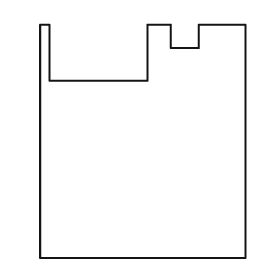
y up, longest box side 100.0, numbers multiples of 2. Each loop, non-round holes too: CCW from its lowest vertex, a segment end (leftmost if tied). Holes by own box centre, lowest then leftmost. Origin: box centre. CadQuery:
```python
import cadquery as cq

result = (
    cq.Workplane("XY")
    .moveTo(-44.0, -50.0)
    .lineTo(44.0, -50.0)
    .lineTo(44.0, 50.0)
    .lineTo(24.0, 50.0)
    .lineTo(24.0, 40.0)
    .lineTo(12.0, 40.0)
    .lineTo(12.0, 50.0)
    .lineTo(2.0, 50.0)
    .lineTo(2.0, 26.0)
    .lineTo(-40.0, 26.0)
    .lineTo(-40.0, 50.0)
    .lineTo(-44.0, 50.0)
    .close()
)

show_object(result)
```